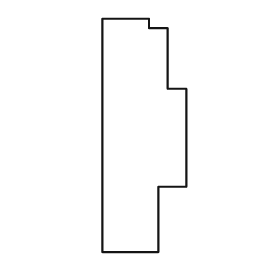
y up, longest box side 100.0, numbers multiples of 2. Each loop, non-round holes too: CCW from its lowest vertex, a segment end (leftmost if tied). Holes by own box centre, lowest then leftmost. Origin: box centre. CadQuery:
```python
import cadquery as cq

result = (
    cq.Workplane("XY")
    .moveTo(-18.0, -50.0)
    .lineTo(6.0, -50.0)
    .lineTo(6.0, -22.0)
    .lineTo(18.0, -22.0)
    .lineTo(18.0, 20.0)
    .lineTo(10.0, 20.0)
    .lineTo(10.0, 46.0)
    .lineTo(2.0, 46.0)
    .lineTo(2.0, 50.0)
    .lineTo(-18.0, 50.0)
    .close()
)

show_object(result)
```